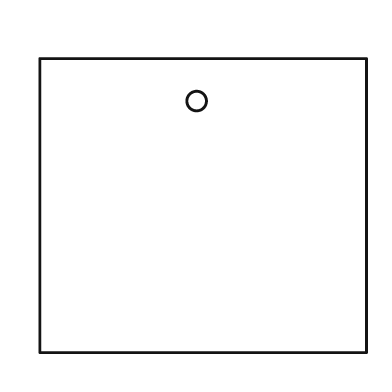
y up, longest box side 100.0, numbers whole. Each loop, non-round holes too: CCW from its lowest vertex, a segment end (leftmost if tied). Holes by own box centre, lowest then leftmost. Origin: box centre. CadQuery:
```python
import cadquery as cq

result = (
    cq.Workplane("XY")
    .moveTo(-50.0, -45.0)
    .lineTo(50.0, -45.0)
    .lineTo(50.0, 45.0)
    .lineTo(-50.0, 45.0)
    .close()
    .moveTo(-2.0, 32.0)
    .circle(3.0)
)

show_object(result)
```